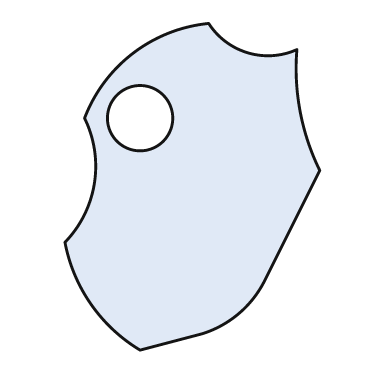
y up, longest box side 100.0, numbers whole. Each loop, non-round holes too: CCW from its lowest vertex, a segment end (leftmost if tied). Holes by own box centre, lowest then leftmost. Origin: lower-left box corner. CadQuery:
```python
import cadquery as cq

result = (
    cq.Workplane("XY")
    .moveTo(23.0, 0.0)
    .lineTo(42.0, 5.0)
    .threePointArc((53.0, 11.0), (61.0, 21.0))
    .lineTo(78.0, 55.0)
    .threePointArc((72.0, 73.0), (71.0, 92.0))
    .threePointArc((56.0, 91.0), (44.0, 100.0))
    .threePointArc((21.0, 91.0), (6.0, 71.0))
    .threePointArc((9.0, 51.0), (0.0, 33.0))
    .threePointArc((8.0, 14.0), (23.0, 0.0))
    .close()
    .moveTo(23.0, 71.0)
    .circle(10.0)
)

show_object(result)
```